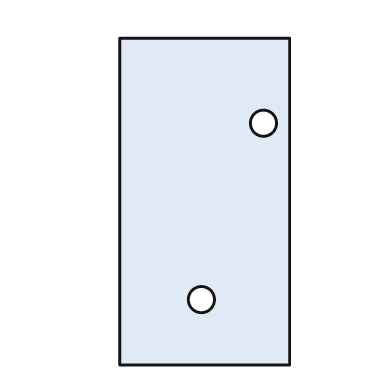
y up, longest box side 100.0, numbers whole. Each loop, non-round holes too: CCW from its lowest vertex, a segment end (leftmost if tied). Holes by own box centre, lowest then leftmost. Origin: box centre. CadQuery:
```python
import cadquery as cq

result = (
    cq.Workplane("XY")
    .moveTo(-26.0, -50.0)
    .lineTo(26.0, -50.0)
    .lineTo(26.0, 50.0)
    .lineTo(-26.0, 50.0)
    .close()
    .moveTo(-1.0, -30.0)
    .circle(4.0)
    .moveTo(18.0, 24.0)
    .circle(4.0)
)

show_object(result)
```